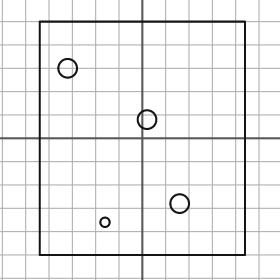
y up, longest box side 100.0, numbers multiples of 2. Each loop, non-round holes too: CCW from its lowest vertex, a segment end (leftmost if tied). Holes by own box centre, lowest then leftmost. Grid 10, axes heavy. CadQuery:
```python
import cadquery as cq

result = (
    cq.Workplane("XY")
    .moveTo(-44.0, -50.0)
    .lineTo(44.0, -50.0)
    .lineTo(44.0, 50.0)
    .lineTo(-44.0, 50.0)
    .close()
    .moveTo(-16.0, -36.0)
    .circle(2.0)
    .moveTo(16.0, -28.0)
    .circle(4.0)
    .moveTo(2.0, 8.0)
    .circle(4.0)
    .moveTo(-32.0, 30.0)
    .circle(4.0)
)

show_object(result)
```